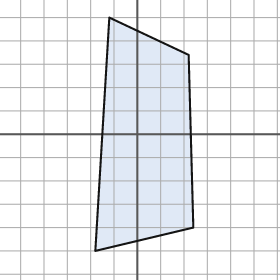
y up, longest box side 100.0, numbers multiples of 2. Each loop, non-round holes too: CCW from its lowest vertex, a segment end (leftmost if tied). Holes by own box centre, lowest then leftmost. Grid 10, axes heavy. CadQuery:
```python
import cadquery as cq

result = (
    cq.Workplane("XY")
    .moveTo(-18.0, -50.0)
    .lineTo(24.0, -40.0)
    .lineTo(22.0, 34.0)
    .lineTo(-12.0, 50.0)
    .close()
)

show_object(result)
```